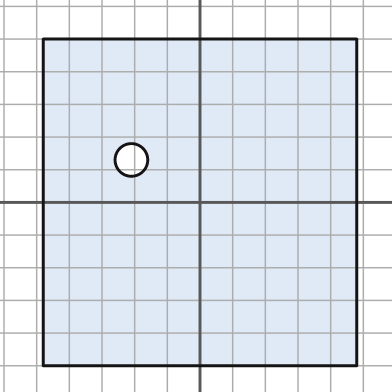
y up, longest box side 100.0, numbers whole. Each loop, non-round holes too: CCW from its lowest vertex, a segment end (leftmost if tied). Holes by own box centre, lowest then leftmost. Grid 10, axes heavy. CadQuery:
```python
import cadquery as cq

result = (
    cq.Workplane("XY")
    .moveTo(-48.0, -50.0)
    .lineTo(48.0, -50.0)
    .lineTo(48.0, 50.0)
    .lineTo(-48.0, 50.0)
    .close()
    .moveTo(-21.0, 13.0)
    .circle(5.0)
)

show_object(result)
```